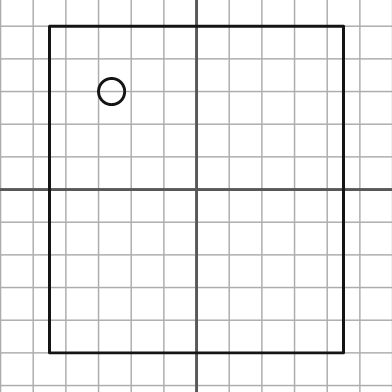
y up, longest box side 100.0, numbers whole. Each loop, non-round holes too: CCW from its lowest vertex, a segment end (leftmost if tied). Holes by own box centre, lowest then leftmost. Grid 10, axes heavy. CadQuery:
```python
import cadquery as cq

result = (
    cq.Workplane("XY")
    .moveTo(-45.0, -50.0)
    .lineTo(45.0, -50.0)
    .lineTo(45.0, 50.0)
    .lineTo(-45.0, 50.0)
    .close()
    .moveTo(-26.0, 30.0)
    .circle(4.0)
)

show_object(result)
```